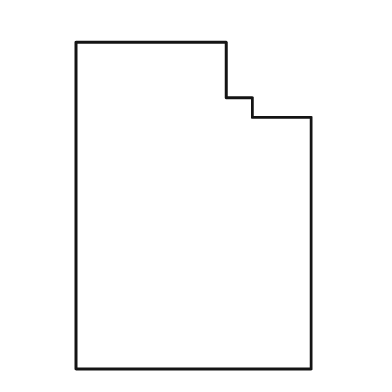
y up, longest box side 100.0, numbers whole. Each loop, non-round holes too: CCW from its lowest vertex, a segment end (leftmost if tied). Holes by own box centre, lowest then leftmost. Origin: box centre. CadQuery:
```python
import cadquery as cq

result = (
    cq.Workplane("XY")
    .moveTo(-36.0, -50.0)
    .lineTo(36.0, -50.0)
    .lineTo(36.0, 27.0)
    .lineTo(18.0, 27.0)
    .lineTo(18.0, 33.0)
    .lineTo(10.0, 33.0)
    .lineTo(10.0, 50.0)
    .lineTo(-36.0, 50.0)
    .close()
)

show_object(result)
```